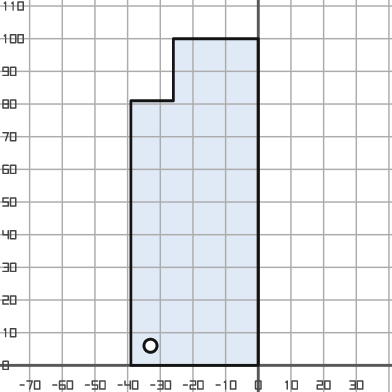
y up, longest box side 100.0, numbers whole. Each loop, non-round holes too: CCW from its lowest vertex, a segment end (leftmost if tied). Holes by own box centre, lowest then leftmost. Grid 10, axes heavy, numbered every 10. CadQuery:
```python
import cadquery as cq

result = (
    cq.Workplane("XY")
    .moveTo(-39.0, 0.0)
    .lineTo(0.0, 0.0)
    .lineTo(0.0, 100.0)
    .lineTo(-26.0, 100.0)
    .lineTo(-26.0, 81.0)
    .lineTo(-39.0, 81.0)
    .close()
    .moveTo(-33.0, 6.0)
    .circle(2.0)
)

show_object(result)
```